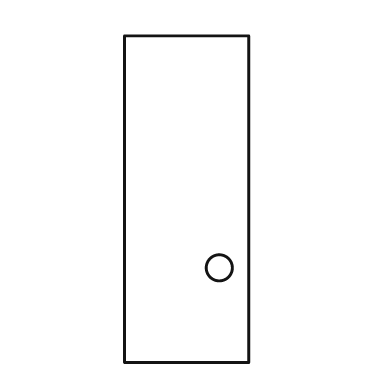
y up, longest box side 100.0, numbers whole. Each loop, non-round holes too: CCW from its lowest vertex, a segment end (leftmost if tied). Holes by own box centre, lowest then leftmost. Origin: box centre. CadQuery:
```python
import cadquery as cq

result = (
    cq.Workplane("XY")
    .moveTo(-19.0, -50.0)
    .lineTo(19.0, -50.0)
    .lineTo(19.0, 50.0)
    .lineTo(-19.0, 50.0)
    .close()
    .moveTo(10.0, -21.0)
    .circle(4.0)
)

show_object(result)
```